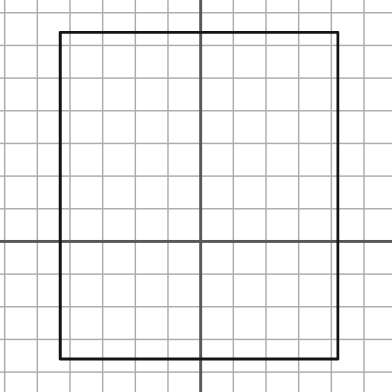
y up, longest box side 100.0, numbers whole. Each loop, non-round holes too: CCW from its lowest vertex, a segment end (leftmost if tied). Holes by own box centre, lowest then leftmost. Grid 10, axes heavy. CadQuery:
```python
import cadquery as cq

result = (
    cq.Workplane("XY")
    .moveTo(-43.0, -36.0)
    .lineTo(42.0, -36.0)
    .lineTo(42.0, 64.0)
    .lineTo(-43.0, 64.0)
    .close()
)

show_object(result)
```